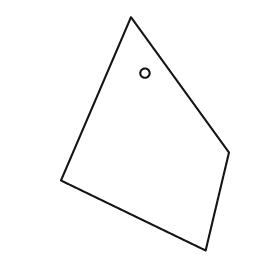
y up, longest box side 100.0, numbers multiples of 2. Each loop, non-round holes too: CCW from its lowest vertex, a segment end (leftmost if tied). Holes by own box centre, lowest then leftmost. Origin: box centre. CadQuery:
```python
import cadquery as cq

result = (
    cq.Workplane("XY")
    .moveTo(26.0, -50.0)
    .lineTo(36.0, -8.0)
    .lineTo(-6.0, 50.0)
    .lineTo(-36.0, -20.0)
    .close()
    .moveTo(0.0, 26.0)
    .circle(2.0)
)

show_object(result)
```